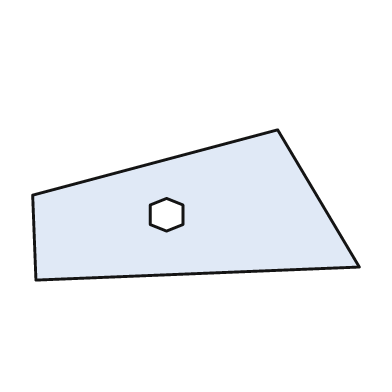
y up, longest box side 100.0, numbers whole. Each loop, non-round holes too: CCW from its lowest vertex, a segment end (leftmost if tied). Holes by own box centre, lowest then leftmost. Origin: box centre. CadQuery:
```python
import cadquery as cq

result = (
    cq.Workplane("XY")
    .moveTo(-49.0, -23.0)
    .lineTo(50.0, -19.0)
    .lineTo(25.0, 23.0)
    .lineTo(-50.0, 3.0)
    .close()
    .moveTo(-9.0, -8.0)
    .lineTo(-4.0, -6.0)
    .lineTo(-4.0, 0.0)
    .lineTo(-9.0, 2.0)
    .lineTo(-14.0, 0.0)
    .lineTo(-14.0, -6.0)
    .close()
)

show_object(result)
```